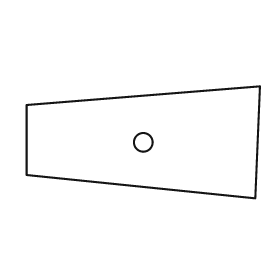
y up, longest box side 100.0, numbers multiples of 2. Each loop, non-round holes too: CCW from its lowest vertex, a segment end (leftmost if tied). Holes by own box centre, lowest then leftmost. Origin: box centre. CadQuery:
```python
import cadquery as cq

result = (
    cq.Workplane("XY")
    .moveTo(48.0, -24.0)
    .lineTo(50.0, 24.0)
    .lineTo(-50.0, 16.0)
    .lineTo(-50.0, -14.0)
    .close()
    .moveTo(0.0, 0.0)
    .circle(4.0)
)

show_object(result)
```